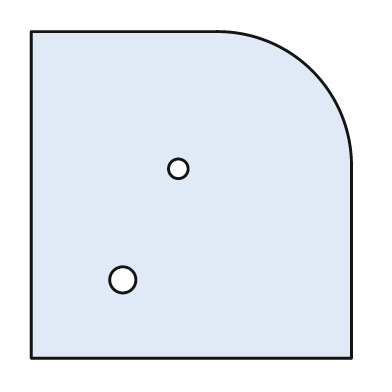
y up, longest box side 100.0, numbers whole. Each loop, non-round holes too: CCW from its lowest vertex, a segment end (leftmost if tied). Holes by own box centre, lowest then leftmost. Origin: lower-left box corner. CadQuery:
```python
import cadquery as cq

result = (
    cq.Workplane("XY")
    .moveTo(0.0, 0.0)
    .lineTo(98.0, 0.0)
    .lineTo(98.0, 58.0)
    .threePointArc((86.0, 88.0), (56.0, 100.0))
    .lineTo(0.0, 100.0)
    .close()
    .moveTo(28.0, 24.0)
    .circle(4.0)
    .moveTo(45.0, 58.0)
    .circle(3.0)
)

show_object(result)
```